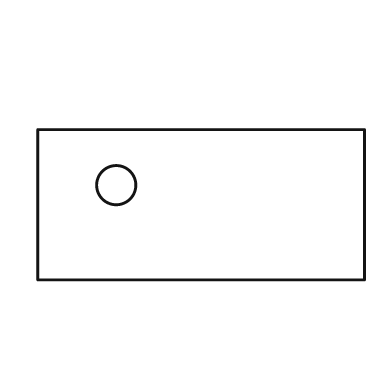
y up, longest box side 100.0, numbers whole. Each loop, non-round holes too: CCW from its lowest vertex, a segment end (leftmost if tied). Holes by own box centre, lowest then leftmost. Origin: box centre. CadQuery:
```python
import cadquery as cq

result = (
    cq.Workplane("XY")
    .moveTo(-50.0, -23.0)
    .lineTo(50.0, -23.0)
    .lineTo(50.0, 23.0)
    .lineTo(-50.0, 23.0)
    .close()
    .moveTo(-26.0, 6.0)
    .circle(6.0)
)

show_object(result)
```